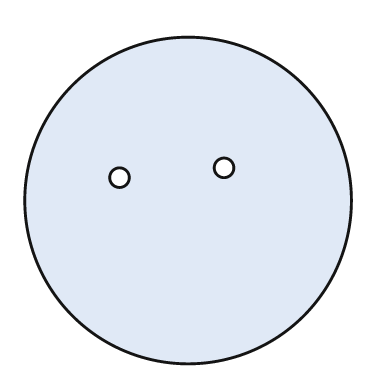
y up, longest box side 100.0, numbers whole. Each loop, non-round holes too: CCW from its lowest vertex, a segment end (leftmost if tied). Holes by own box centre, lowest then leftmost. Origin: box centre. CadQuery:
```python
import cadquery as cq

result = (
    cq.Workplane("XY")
    .moveTo(0.0, 0.0)
    .circle(50.0)
    .moveTo(-21.0, 7.0)
    .circle(3.0)
    .moveTo(11.0, 10.0)
    .circle(3.0)
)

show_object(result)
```